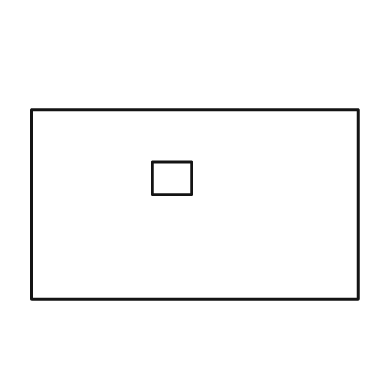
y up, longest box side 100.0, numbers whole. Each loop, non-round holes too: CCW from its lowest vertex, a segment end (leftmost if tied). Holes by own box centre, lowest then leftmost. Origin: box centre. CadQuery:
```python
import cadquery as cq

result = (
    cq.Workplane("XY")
    .moveTo(-50.0, -29.0)
    .lineTo(50.0, -29.0)
    .lineTo(50.0, 29.0)
    .lineTo(-50.0, 29.0)
    .close()
    .moveTo(-13.0, 3.0)
    .lineTo(-1.0, 3.0)
    .lineTo(-1.0, 13.0)
    .lineTo(-13.0, 13.0)
    .close()
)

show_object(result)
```